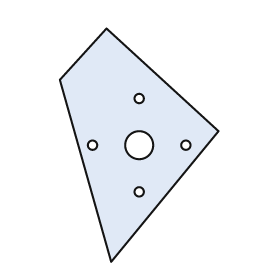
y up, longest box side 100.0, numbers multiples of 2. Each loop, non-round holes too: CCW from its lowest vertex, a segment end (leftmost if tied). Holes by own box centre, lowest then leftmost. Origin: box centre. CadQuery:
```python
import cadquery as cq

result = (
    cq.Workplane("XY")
    .moveTo(-12.0, -50.0)
    .lineTo(34.0, 6.0)
    .lineTo(-14.0, 50.0)
    .lineTo(-34.0, 28.0)
    .close()
    .moveTo(0.0, -20.0)
    .circle(2.0)
    .moveTo(-20.0, 0.0)
    .circle(2.0)
    .moveTo(0.0, 0.0)
    .circle(6.0)
    .moveTo(20.0, 0.0)
    .circle(2.0)
    .moveTo(0.0, 20.0)
    .circle(2.0)
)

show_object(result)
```